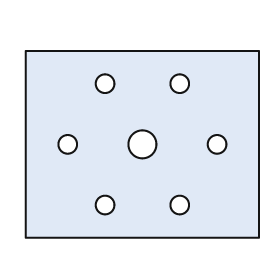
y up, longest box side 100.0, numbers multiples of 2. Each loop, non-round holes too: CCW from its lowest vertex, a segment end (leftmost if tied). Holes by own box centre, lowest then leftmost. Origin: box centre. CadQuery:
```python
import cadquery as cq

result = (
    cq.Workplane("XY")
    .moveTo(-50.0, -40.0)
    .lineTo(50.0, -40.0)
    .lineTo(50.0, 40.0)
    .lineTo(-50.0, 40.0)
    .close()
    .moveTo(-16.0, -26.0)
    .circle(4.0)
    .moveTo(16.0, -26.0)
    .circle(4.0)
    .moveTo(-32.0, 0.0)
    .circle(4.0)
    .moveTo(0.0, 0.0)
    .circle(6.0)
    .moveTo(32.0, 0.0)
    .circle(4.0)
    .moveTo(-16.0, 26.0)
    .circle(4.0)
    .moveTo(16.0, 26.0)
    .circle(4.0)
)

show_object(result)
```